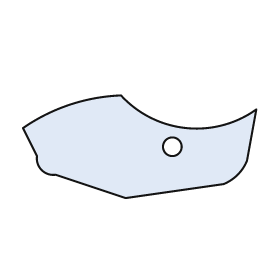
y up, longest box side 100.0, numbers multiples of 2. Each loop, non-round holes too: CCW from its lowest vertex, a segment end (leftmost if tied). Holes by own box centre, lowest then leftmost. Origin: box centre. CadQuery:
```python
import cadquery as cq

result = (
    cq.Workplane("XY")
    .moveTo(-6.0, -22.0)
    .lineTo(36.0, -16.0)
    .threePointArc((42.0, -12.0), (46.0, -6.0))
    .lineTo(50.0, 16.0)
    .threePointArc((20.0, 8.0), (-8.0, 22.0))
    .threePointArc((-30.0, 18.0), (-50.0, 8.0))
    .lineTo(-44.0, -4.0)
    .threePointArc((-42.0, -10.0), (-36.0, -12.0))
    .close()
    .moveTo(14.0, 0.0)
    .circle(4.0)
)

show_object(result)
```